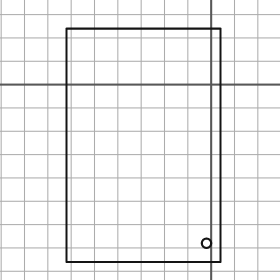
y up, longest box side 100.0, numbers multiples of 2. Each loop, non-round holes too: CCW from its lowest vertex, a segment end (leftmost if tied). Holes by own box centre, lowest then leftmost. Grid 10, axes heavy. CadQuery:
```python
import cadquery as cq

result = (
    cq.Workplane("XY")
    .moveTo(-62.0, -76.0)
    .lineTo(4.0, -76.0)
    .lineTo(4.0, 24.0)
    .lineTo(-62.0, 24.0)
    .close()
    .moveTo(-2.0, -68.0)
    .circle(2.0)
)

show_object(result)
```